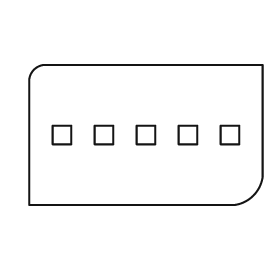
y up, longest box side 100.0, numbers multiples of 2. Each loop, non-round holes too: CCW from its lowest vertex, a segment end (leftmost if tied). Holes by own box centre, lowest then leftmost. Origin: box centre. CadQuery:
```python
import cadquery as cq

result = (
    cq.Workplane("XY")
    .moveTo(-50.0, -30.0)
    .lineTo(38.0, -30.0)
    .threePointArc((46.0, -26.0), (50.0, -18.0))
    .lineTo(50.0, 30.0)
    .lineTo(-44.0, 30.0)
    .threePointArc((-48.0, 28.0), (-50.0, 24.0))
    .close()
    .moveTo(-40.0, -4.0)
    .lineTo(-32.0, -4.0)
    .lineTo(-32.0, 4.0)
    .lineTo(-40.0, 4.0)
    .close()
    .moveTo(-22.0, -4.0)
    .lineTo(-14.0, -4.0)
    .lineTo(-14.0, 4.0)
    .lineTo(-22.0, 4.0)
    .close()
    .moveTo(-4.0, -4.0)
    .lineTo(4.0, -4.0)
    .lineTo(4.0, 4.0)
    .lineTo(-4.0, 4.0)
    .close()
    .moveTo(14.0, -4.0)
    .lineTo(22.0, -4.0)
    .lineTo(22.0, 4.0)
    .lineTo(14.0, 4.0)
    .close()
    .moveTo(32.0, -4.0)
    .lineTo(40.0, -4.0)
    .lineTo(40.0, 4.0)
    .lineTo(32.0, 4.0)
    .close()
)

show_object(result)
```